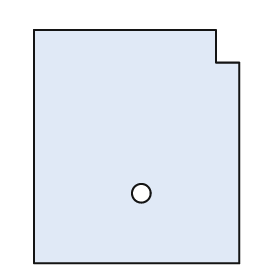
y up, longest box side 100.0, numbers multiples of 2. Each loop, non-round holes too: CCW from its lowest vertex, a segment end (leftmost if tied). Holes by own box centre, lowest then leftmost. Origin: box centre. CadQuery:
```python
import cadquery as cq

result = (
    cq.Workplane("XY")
    .moveTo(-44.0, -50.0)
    .lineTo(44.0, -50.0)
    .lineTo(44.0, 36.0)
    .lineTo(34.0, 36.0)
    .lineTo(34.0, 50.0)
    .lineTo(-44.0, 50.0)
    .close()
    .moveTo(2.0, -20.0)
    .circle(4.0)
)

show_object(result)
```